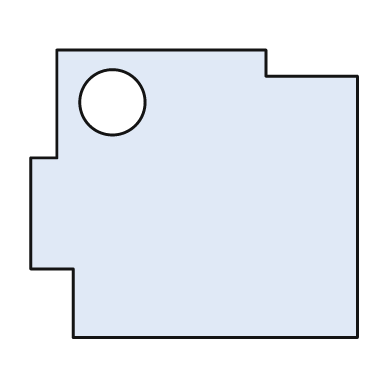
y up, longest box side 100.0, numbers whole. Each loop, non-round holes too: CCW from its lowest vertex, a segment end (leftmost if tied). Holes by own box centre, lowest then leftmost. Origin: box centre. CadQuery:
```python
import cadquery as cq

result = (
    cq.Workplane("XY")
    .moveTo(-37.0, -44.0)
    .lineTo(50.0, -44.0)
    .lineTo(50.0, 36.0)
    .lineTo(22.0, 36.0)
    .lineTo(22.0, 44.0)
    .lineTo(-42.0, 44.0)
    .lineTo(-42.0, 11.0)
    .lineTo(-50.0, 11.0)
    .lineTo(-50.0, -23.0)
    .lineTo(-37.0, -23.0)
    .close()
    .moveTo(-25.0, 28.0)
    .circle(10.0)
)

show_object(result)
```